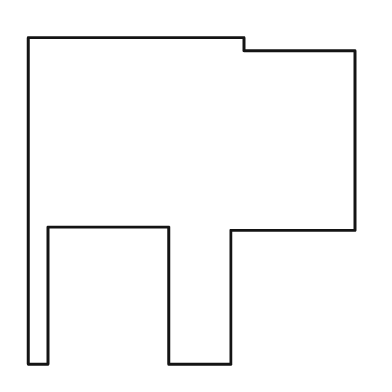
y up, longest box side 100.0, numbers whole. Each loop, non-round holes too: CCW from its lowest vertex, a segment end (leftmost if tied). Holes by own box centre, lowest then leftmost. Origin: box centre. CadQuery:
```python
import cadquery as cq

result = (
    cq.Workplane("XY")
    .moveTo(-50.0, -50.0)
    .lineTo(-44.0, -50.0)
    .lineTo(-44.0, -8.0)
    .lineTo(-7.0, -8.0)
    .lineTo(-7.0, -50.0)
    .lineTo(12.0, -50.0)
    .lineTo(12.0, -9.0)
    .lineTo(50.0, -9.0)
    .lineTo(50.0, 46.0)
    .lineTo(16.0, 46.0)
    .lineTo(16.0, 50.0)
    .lineTo(-50.0, 50.0)
    .close()
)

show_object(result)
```